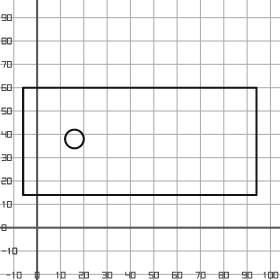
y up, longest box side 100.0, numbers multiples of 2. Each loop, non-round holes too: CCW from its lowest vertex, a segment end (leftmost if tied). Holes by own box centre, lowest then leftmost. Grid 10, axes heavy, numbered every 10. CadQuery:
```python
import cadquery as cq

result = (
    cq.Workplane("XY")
    .moveTo(-6.0, 14.0)
    .lineTo(94.0, 14.0)
    .lineTo(94.0, 60.0)
    .lineTo(-6.0, 60.0)
    .close()
    .moveTo(16.0, 38.0)
    .circle(4.0)
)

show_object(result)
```